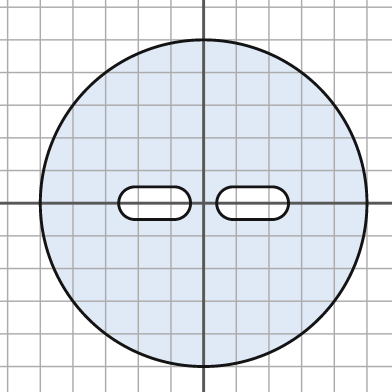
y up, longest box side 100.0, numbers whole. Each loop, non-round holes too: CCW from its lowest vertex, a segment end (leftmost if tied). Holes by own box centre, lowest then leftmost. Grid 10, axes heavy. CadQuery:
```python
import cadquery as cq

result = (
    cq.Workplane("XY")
    .moveTo(0.0, 0.0)
    .circle(50.0)
    .moveTo(-21.0, -5.0)
    .lineTo(-9.0, -5.0)
    .threePointArc((-4.0, 0.0), (-9.0, 5.0))
    .lineTo(-21.0, 5.0)
    .threePointArc((-26.0, 0.0), (-21.0, -5.0))
    .close()
    .moveTo(9.0, -5.0)
    .lineTo(21.0, -5.0)
    .threePointArc((26.0, 0.0), (21.0, 5.0))
    .lineTo(9.0, 5.0)
    .threePointArc((4.0, 0.0), (9.0, -5.0))
    .close()
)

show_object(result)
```